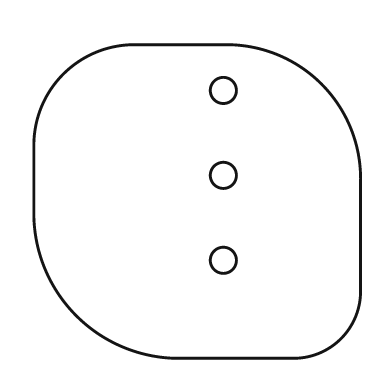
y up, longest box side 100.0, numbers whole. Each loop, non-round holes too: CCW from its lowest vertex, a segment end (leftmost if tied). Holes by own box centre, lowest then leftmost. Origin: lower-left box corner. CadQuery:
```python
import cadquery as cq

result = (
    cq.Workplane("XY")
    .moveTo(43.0, 0.0)
    .lineTo(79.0, 0.0)
    .threePointArc((94.0, 6.0), (100.0, 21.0))
    .lineTo(100.0, 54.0)
    .threePointArc((88.0, 84.0), (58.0, 96.0))
    .lineTo(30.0, 96.0)
    .threePointArc((9.0, 87.0), (0.0, 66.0))
    .lineTo(0.0, 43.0)
    .threePointArc((13.0, 13.0), (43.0, 0.0))
    .close()
    .moveTo(58.0, 30.0)
    .circle(4.0)
    .moveTo(58.0, 56.0)
    .circle(4.0)
    .moveTo(58.0, 82.0)
    .circle(4.0)
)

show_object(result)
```